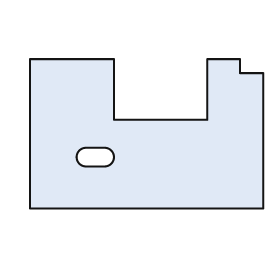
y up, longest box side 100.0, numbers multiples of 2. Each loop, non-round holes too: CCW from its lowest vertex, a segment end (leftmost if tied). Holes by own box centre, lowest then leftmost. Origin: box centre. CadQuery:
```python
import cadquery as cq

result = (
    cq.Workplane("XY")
    .moveTo(-50.0, -32.0)
    .lineTo(50.0, -32.0)
    .lineTo(50.0, 26.0)
    .lineTo(40.0, 26.0)
    .lineTo(40.0, 32.0)
    .lineTo(26.0, 32.0)
    .lineTo(26.0, 6.0)
    .lineTo(-14.0, 6.0)
    .lineTo(-14.0, 32.0)
    .lineTo(-50.0, 32.0)
    .close()
    .moveTo(-26.0, -14.0)
    .lineTo(-18.0, -14.0)
    .threePointArc((-14.0, -10.0), (-18.0, -6.0))
    .lineTo(-26.0, -6.0)
    .threePointArc((-30.0, -10.0), (-26.0, -14.0))
    .close()
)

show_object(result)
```